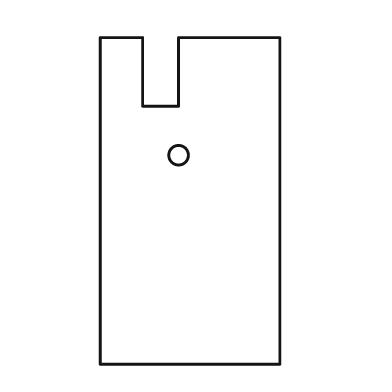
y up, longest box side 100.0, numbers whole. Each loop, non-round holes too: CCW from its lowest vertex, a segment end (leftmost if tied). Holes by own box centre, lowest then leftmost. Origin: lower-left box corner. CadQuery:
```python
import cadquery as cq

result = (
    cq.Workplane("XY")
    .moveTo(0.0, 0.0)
    .lineTo(55.0, 0.0)
    .lineTo(55.0, 100.0)
    .lineTo(24.0, 100.0)
    .lineTo(24.0, 79.0)
    .lineTo(13.0, 79.0)
    .lineTo(13.0, 100.0)
    .lineTo(0.0, 100.0)
    .close()
    .moveTo(24.0, 64.0)
    .circle(3.0)
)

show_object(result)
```